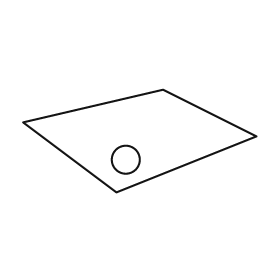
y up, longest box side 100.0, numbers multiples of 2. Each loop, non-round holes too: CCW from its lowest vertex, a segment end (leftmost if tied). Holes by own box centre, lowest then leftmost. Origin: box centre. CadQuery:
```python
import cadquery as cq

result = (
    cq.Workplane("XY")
    .moveTo(-10.0, -22.0)
    .lineTo(50.0, 2.0)
    .lineTo(10.0, 22.0)
    .lineTo(-50.0, 8.0)
    .close()
    .moveTo(-6.0, -8.0)
    .circle(6.0)
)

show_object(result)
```